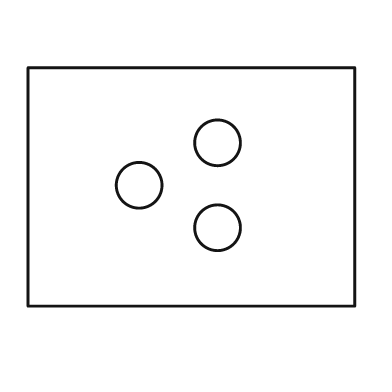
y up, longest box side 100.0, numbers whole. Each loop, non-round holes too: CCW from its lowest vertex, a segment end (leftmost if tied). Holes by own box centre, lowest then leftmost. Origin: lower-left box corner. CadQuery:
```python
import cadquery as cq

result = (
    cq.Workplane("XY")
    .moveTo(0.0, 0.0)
    .lineTo(100.0, 0.0)
    .lineTo(100.0, 73.0)
    .lineTo(0.0, 73.0)
    .close()
    .moveTo(58.0, 24.0)
    .circle(7.0)
    .moveTo(34.0, 37.0)
    .circle(7.0)
    .moveTo(58.0, 50.0)
    .circle(7.0)
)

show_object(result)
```